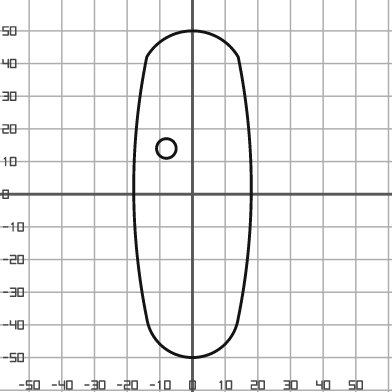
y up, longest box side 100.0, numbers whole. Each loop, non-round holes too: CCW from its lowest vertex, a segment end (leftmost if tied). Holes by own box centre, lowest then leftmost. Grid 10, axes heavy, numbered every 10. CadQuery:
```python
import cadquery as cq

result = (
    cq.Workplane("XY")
    .moveTo(-14.0, -38.0)
    .threePointArc((0.0, -50.0), (14.0, -38.0))
    .threePointArc((18.0, 2.0), (14.0, 42.0))
    .threePointArc((0.0, 50.0), (-14.0, 42.0))
    .threePointArc((-18.0, 2.0), (-14.0, -38.0))
    .close()
    .moveTo(-8.0, 14.0)
    .circle(3.0)
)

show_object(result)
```